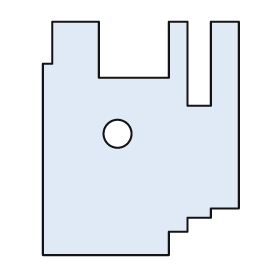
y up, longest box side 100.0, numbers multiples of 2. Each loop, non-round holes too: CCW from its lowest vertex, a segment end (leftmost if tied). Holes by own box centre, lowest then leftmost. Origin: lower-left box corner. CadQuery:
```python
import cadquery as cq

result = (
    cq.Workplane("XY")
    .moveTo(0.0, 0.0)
    .lineTo(54.0, 0.0)
    .lineTo(54.0, 10.0)
    .lineTo(62.0, 10.0)
    .lineTo(62.0, 16.0)
    .lineTo(72.0, 16.0)
    .lineTo(72.0, 20.0)
    .lineTo(84.0, 20.0)
    .lineTo(84.0, 100.0)
    .lineTo(72.0, 100.0)
    .lineTo(72.0, 64.0)
    .lineTo(62.0, 64.0)
    .lineTo(62.0, 100.0)
    .lineTo(54.0, 100.0)
    .lineTo(54.0, 76.0)
    .lineTo(24.0, 76.0)
    .lineTo(24.0, 100.0)
    .lineTo(4.0, 100.0)
    .lineTo(4.0, 82.0)
    .lineTo(0.0, 82.0)
    .close()
    .moveTo(32.0, 52.0)
    .circle(6.0)
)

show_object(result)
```